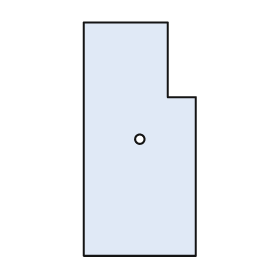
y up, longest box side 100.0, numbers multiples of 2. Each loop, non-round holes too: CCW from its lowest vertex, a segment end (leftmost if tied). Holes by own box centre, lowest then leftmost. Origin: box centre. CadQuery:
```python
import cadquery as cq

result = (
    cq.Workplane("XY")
    .moveTo(-24.0, -50.0)
    .lineTo(24.0, -50.0)
    .lineTo(24.0, 18.0)
    .lineTo(12.0, 18.0)
    .lineTo(12.0, 50.0)
    .lineTo(-24.0, 50.0)
    .close()
    .moveTo(0.0, 0.0)
    .circle(2.0)
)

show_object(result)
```